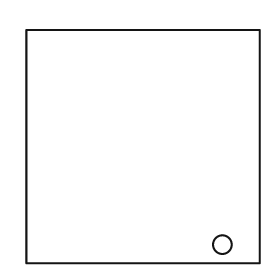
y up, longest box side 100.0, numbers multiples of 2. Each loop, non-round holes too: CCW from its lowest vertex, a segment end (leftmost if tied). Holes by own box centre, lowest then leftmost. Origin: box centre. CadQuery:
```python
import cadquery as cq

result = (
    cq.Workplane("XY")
    .moveTo(-50.0, -50.0)
    .lineTo(50.0, -50.0)
    .lineTo(50.0, 50.0)
    .lineTo(-50.0, 50.0)
    .close()
    .moveTo(34.0, -42.0)
    .circle(4.0)
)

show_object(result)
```